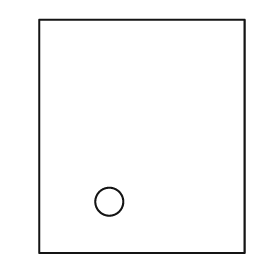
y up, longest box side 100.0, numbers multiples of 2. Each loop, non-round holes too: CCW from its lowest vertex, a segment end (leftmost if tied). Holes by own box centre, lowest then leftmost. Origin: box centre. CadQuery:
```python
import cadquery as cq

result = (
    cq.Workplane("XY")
    .moveTo(-44.0, -50.0)
    .lineTo(44.0, -50.0)
    .lineTo(44.0, 50.0)
    .lineTo(-44.0, 50.0)
    .close()
    .moveTo(-14.0, -28.0)
    .circle(6.0)
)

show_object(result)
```